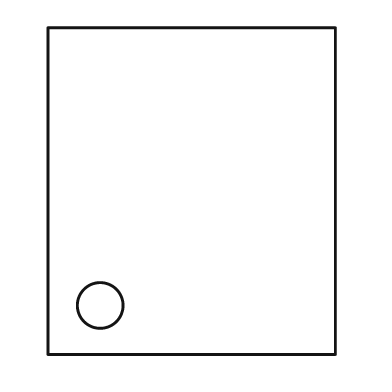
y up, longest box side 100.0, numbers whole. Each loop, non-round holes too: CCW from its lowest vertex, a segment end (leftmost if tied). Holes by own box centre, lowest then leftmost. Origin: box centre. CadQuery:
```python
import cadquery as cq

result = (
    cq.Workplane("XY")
    .moveTo(-44.0, -50.0)
    .lineTo(44.0, -50.0)
    .lineTo(44.0, 50.0)
    .lineTo(-44.0, 50.0)
    .close()
    .moveTo(-28.0, -35.0)
    .circle(7.0)
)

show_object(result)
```